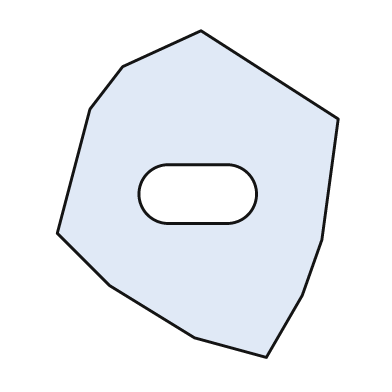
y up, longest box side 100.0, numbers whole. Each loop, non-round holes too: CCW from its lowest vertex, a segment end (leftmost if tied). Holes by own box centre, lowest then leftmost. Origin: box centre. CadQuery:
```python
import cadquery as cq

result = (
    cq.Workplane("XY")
    .moveTo(21.0, -50.0)
    .lineTo(32.0, -31.0)
    .lineTo(38.0, -14.0)
    .lineTo(43.0, 23.0)
    .lineTo(1.0, 50.0)
    .lineTo(-23.0, 39.0)
    .lineTo(-33.0, 26.0)
    .lineTo(-43.0, -12.0)
    .lineTo(-27.0, -28.0)
    .lineTo(-1.0, -44.0)
    .close()
    .moveTo(-9.0, -9.0)
    .lineTo(9.0, -9.0)
    .threePointArc((18.0, 0.0), (9.0, 9.0))
    .lineTo(-9.0, 9.0)
    .threePointArc((-18.0, 0.0), (-9.0, -9.0))
    .close()
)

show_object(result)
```